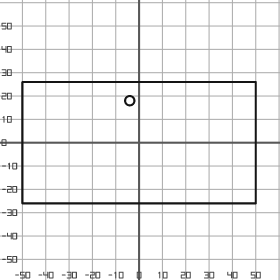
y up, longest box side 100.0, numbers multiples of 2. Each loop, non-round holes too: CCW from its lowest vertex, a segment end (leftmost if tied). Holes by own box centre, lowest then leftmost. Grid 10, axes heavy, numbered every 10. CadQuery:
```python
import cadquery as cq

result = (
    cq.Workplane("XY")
    .moveTo(-50.0, -26.0)
    .lineTo(50.0, -26.0)
    .lineTo(50.0, 26.0)
    .lineTo(-50.0, 26.0)
    .close()
    .moveTo(-4.0, 18.0)
    .circle(2.0)
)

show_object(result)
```